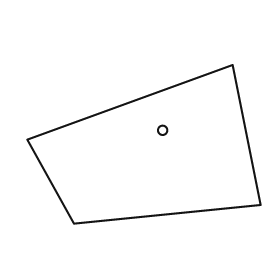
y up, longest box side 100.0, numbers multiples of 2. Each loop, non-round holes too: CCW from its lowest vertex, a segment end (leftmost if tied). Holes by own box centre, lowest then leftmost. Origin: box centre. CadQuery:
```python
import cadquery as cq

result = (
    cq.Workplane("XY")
    .moveTo(-30.0, -34.0)
    .lineTo(50.0, -26.0)
    .lineTo(38.0, 34.0)
    .lineTo(-50.0, 2.0)
    .close()
    .moveTo(8.0, 6.0)
    .circle(2.0)
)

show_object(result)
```